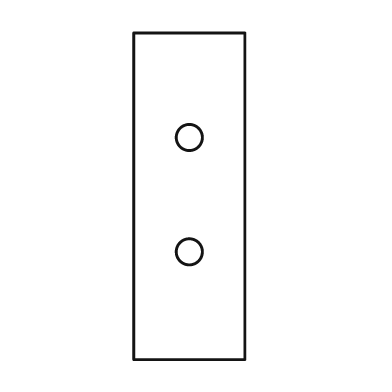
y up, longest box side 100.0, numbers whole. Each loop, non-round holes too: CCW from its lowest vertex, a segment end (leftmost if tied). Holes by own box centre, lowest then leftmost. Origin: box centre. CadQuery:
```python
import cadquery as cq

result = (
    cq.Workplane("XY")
    .moveTo(-17.0, -50.0)
    .lineTo(17.0, -50.0)
    .lineTo(17.0, 50.0)
    .lineTo(-17.0, 50.0)
    .close()
    .moveTo(0.0, -17.0)
    .circle(4.0)
    .moveTo(0.0, 18.0)
    .circle(4.0)
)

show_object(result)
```